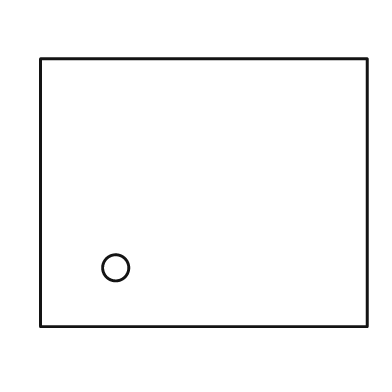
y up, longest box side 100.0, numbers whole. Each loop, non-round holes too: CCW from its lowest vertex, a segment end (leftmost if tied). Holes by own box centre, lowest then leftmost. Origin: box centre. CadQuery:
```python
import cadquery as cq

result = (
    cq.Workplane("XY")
    .moveTo(-50.0, -41.0)
    .lineTo(50.0, -41.0)
    .lineTo(50.0, 41.0)
    .lineTo(-50.0, 41.0)
    .close()
    .moveTo(-27.0, -23.0)
    .circle(4.0)
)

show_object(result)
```